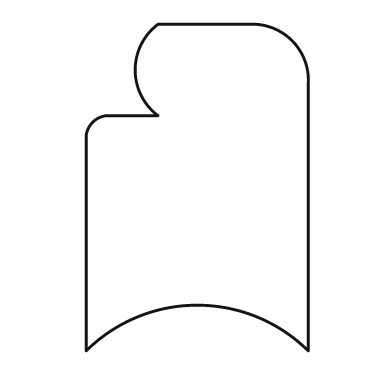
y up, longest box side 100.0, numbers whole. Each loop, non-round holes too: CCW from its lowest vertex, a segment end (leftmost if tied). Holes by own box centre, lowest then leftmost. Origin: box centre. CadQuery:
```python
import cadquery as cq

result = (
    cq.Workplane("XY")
    .moveTo(-34.0, -50.0)
    .threePointArc((0.0, -36.0), (34.0, -50.0))
    .lineTo(34.0, 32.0)
    .threePointArc((29.0, 45.0), (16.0, 50.0))
    .lineTo(-12.0, 50.0)
    .threePointArc((-19.0, 36.0), (-12.0, 22.0))
    .lineTo(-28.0, 22.0)
    .threePointArc((-32.0, 20.0), (-34.0, 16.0))
    .close()
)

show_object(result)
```